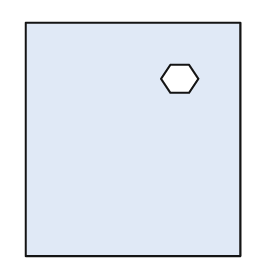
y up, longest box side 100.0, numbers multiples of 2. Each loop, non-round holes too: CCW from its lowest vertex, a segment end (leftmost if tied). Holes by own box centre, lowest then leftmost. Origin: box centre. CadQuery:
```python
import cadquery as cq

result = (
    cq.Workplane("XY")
    .moveTo(-46.0, -50.0)
    .lineTo(46.0, -50.0)
    .lineTo(46.0, 50.0)
    .lineTo(-46.0, 50.0)
    .close()
    .moveTo(16.0, 20.0)
    .lineTo(24.0, 20.0)
    .lineTo(28.0, 26.0)
    .lineTo(24.0, 32.0)
    .lineTo(16.0, 32.0)
    .lineTo(12.0, 26.0)
    .close()
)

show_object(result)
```